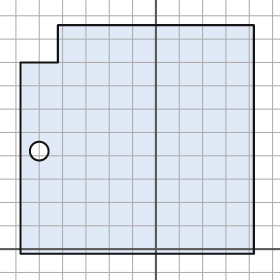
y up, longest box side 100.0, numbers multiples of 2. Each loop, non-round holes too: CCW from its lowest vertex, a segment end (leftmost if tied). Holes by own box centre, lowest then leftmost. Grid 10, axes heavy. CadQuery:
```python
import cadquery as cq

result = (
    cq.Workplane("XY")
    .moveTo(-58.0, -2.0)
    .lineTo(42.0, -2.0)
    .lineTo(42.0, 96.0)
    .lineTo(-42.0, 96.0)
    .lineTo(-42.0, 80.0)
    .lineTo(-58.0, 80.0)
    .close()
    .moveTo(-50.0, 42.0)
    .circle(4.0)
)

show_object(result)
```